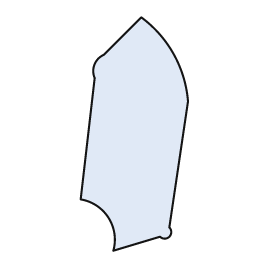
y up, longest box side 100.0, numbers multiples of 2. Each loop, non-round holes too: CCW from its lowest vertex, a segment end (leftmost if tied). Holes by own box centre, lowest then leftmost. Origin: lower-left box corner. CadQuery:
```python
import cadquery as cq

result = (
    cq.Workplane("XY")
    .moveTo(14.0, 0.0)
    .lineTo(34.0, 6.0)
    .threePointArc((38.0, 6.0), (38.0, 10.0))
    .lineTo(46.0, 64.0)
    .threePointArc((40.0, 84.0), (26.0, 100.0))
    .lineTo(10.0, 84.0)
    .threePointArc((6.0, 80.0), (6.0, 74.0))
    .lineTo(0.0, 22.0)
    .threePointArc((12.0, 14.0), (14.0, 0.0))
    .close()
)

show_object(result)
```